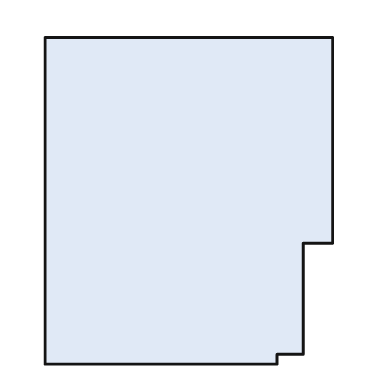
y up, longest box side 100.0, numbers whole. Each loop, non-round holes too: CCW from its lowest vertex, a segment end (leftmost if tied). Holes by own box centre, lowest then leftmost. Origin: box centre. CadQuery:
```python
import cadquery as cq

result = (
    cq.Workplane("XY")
    .moveTo(-44.0, -50.0)
    .lineTo(27.0, -50.0)
    .lineTo(27.0, -47.0)
    .lineTo(35.0, -47.0)
    .lineTo(35.0, -13.0)
    .lineTo(44.0, -13.0)
    .lineTo(44.0, 50.0)
    .lineTo(-44.0, 50.0)
    .close()
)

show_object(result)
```